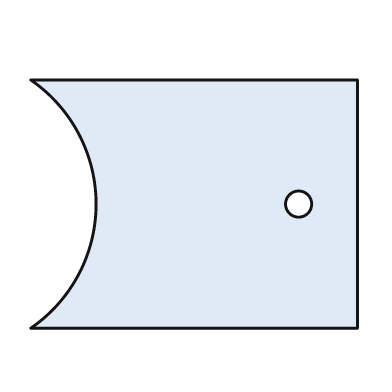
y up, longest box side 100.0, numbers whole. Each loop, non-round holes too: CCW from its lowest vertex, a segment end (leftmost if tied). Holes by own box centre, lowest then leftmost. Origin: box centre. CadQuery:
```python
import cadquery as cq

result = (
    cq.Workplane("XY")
    .moveTo(-50.0, -38.0)
    .lineTo(50.0, -38.0)
    .lineTo(50.0, 38.0)
    .lineTo(-50.0, 38.0)
    .threePointArc((-30.0, 0.0), (-50.0, -38.0))
    .close()
    .moveTo(32.0, 0.0)
    .circle(4.0)
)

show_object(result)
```